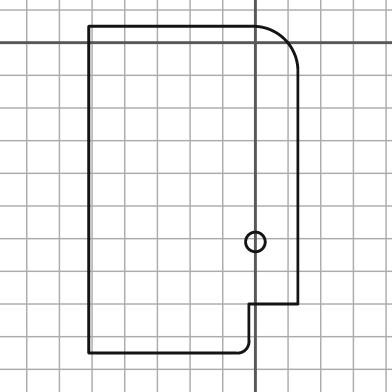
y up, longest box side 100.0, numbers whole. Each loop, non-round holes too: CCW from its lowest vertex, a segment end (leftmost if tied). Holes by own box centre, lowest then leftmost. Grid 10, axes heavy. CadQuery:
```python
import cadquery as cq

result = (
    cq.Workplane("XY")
    .moveTo(-51.0, -95.0)
    .lineTo(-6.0, -95.0)
    .threePointArc((-3.0, -94.0), (-2.0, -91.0))
    .lineTo(-2.0, -80.0)
    .lineTo(13.0, -80.0)
    .lineTo(13.0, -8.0)
    .threePointArc((9.0, 1.0), (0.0, 5.0))
    .lineTo(-51.0, 5.0)
    .close()
    .moveTo(0.0, -61.0)
    .circle(3.0)
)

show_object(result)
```